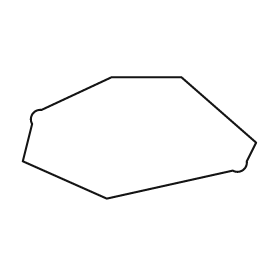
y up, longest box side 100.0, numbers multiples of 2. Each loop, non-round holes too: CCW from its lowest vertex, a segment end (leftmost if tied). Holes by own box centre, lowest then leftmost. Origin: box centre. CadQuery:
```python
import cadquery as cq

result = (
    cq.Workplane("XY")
    .moveTo(-14.0, -26.0)
    .lineTo(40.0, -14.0)
    .threePointArc((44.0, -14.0), (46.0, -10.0))
    .lineTo(50.0, -2.0)
    .lineTo(18.0, 26.0)
    .lineTo(-12.0, 26.0)
    .lineTo(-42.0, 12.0)
    .threePointArc((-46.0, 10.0), (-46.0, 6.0))
    .lineTo(-50.0, -10.0)
    .close()
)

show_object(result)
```